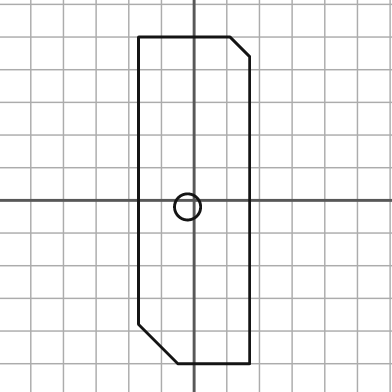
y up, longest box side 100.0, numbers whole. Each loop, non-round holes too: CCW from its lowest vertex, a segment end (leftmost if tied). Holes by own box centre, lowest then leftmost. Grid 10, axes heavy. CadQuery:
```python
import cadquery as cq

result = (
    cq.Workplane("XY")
    .moveTo(-5.0, -50.0)
    .lineTo(17.0, -50.0)
    .lineTo(17.0, 44.0)
    .lineTo(11.0, 50.0)
    .lineTo(-17.0, 50.0)
    .lineTo(-17.0, -38.0)
    .close()
    .moveTo(-2.0, -2.0)
    .circle(4.0)
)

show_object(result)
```